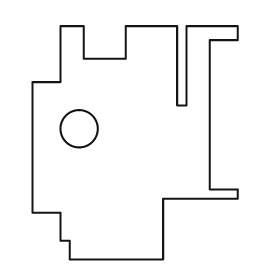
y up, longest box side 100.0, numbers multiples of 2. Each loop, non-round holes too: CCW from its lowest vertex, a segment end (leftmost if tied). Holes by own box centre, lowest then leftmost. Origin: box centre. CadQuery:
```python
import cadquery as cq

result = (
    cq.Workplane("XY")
    .moveTo(-28.0, -50.0)
    .lineTo(12.0, -50.0)
    .lineTo(12.0, -24.0)
    .lineTo(44.0, -24.0)
    .lineTo(44.0, -20.0)
    .lineTo(32.0, -20.0)
    .lineTo(32.0, 44.0)
    .lineTo(44.0, 44.0)
    .lineTo(44.0, 50.0)
    .lineTo(22.0, 50.0)
    .lineTo(22.0, 16.0)
    .lineTo(18.0, 16.0)
    .lineTo(18.0, 50.0)
    .lineTo(-4.0, 50.0)
    .lineTo(-4.0, 36.0)
    .lineTo(-22.0, 36.0)
    .lineTo(-22.0, 50.0)
    .lineTo(-32.0, 50.0)
    .lineTo(-32.0, 26.0)
    .lineTo(-44.0, 26.0)
    .lineTo(-44.0, -30.0)
    .lineTo(-32.0, -30.0)
    .lineTo(-32.0, -42.0)
    .lineTo(-28.0, -42.0)
    .close()
    .moveTo(-24.0, 6.0)
    .circle(8.0)
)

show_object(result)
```